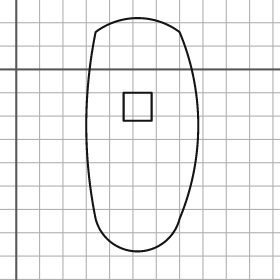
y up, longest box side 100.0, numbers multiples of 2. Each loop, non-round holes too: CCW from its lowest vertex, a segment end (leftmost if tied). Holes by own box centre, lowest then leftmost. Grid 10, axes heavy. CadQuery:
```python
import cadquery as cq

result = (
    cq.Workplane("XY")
    .moveTo(34.0, -64.0)
    .threePointArc((52.0, -78.0), (70.0, -64.0))
    .threePointArc((78.0, -24.0), (70.0, 16.0))
    .threePointArc((52.0, 22.0), (34.0, 16.0))
    .threePointArc((30.0, -24.0), (34.0, -64.0))
    .close()
    .moveTo(46.0, -22.0)
    .lineTo(58.0, -22.0)
    .lineTo(58.0, -10.0)
    .lineTo(46.0, -10.0)
    .close()
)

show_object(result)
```